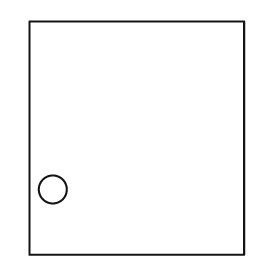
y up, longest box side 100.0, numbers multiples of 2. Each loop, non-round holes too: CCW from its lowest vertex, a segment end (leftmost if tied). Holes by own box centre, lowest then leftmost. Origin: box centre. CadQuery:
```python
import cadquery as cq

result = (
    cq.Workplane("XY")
    .moveTo(-46.0, -50.0)
    .lineTo(46.0, -50.0)
    .lineTo(46.0, 50.0)
    .lineTo(-46.0, 50.0)
    .close()
    .moveTo(-36.0, -22.0)
    .circle(6.0)
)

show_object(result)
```